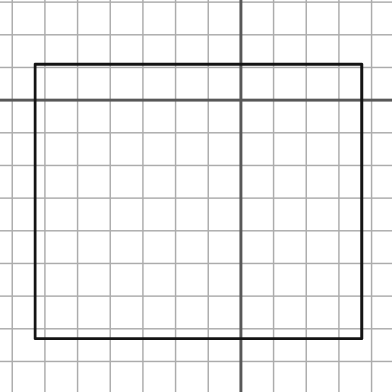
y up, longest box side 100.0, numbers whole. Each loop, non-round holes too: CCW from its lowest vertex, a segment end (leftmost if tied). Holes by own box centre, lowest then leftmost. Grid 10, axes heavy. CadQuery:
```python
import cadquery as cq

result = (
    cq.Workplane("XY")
    .moveTo(-63.0, -73.0)
    .lineTo(37.0, -73.0)
    .lineTo(37.0, 11.0)
    .lineTo(-63.0, 11.0)
    .close()
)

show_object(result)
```